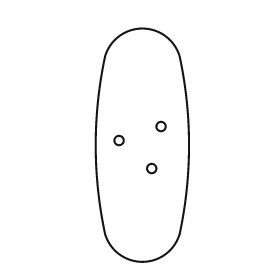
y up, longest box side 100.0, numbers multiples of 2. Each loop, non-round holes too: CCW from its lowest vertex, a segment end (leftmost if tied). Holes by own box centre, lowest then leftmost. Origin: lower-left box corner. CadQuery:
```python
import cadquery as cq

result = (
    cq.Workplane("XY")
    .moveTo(4.0, 12.0)
    .threePointArc((20.0, 0.0), (36.0, 12.0))
    .threePointArc((40.0, 50.0), (36.0, 88.0))
    .threePointArc((20.0, 100.0), (4.0, 88.0))
    .threePointArc((0.0, 50.0), (4.0, 12.0))
    .close()
    .moveTo(24.0, 40.0)
    .circle(2.0)
    .moveTo(10.0, 52.0)
    .circle(2.0)
    .moveTo(28.0, 58.0)
    .circle(2.0)
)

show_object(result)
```